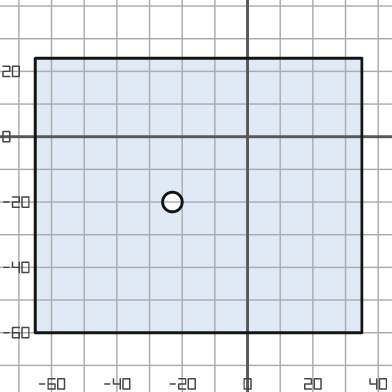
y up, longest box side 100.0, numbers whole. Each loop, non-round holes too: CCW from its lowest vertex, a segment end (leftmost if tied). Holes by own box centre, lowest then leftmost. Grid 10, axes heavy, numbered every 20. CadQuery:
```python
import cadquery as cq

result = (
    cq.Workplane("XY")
    .moveTo(-65.0, -60.0)
    .lineTo(35.0, -60.0)
    .lineTo(35.0, 24.0)
    .lineTo(-65.0, 24.0)
    .close()
    .moveTo(-23.0, -20.0)
    .circle(3.0)
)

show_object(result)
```